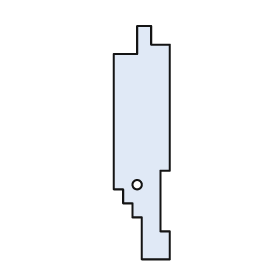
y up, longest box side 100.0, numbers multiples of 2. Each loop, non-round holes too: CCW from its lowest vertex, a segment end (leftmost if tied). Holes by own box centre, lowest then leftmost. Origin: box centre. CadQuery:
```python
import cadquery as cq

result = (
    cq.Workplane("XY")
    .moveTo(0.0, -50.0)
    .lineTo(12.0, -50.0)
    .lineTo(12.0, -38.0)
    .lineTo(8.0, -38.0)
    .lineTo(8.0, -12.0)
    .lineTo(12.0, -12.0)
    .lineTo(12.0, 42.0)
    .lineTo(4.0, 42.0)
    .lineTo(4.0, 50.0)
    .lineTo(-2.0, 50.0)
    .lineTo(-2.0, 38.0)
    .lineTo(-12.0, 38.0)
    .lineTo(-12.0, -20.0)
    .lineTo(-8.0, -20.0)
    .lineTo(-8.0, -26.0)
    .lineTo(-4.0, -26.0)
    .lineTo(-4.0, -32.0)
    .lineTo(0.0, -32.0)
    .close()
    .moveTo(-2.0, -18.0)
    .circle(2.0)
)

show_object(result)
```